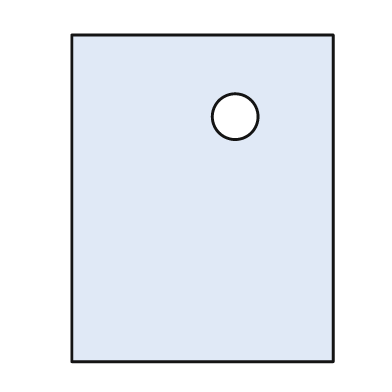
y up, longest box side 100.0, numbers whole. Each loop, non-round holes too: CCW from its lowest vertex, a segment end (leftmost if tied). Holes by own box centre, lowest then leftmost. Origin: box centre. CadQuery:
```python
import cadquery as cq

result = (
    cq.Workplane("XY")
    .moveTo(-40.0, -50.0)
    .lineTo(40.0, -50.0)
    .lineTo(40.0, 50.0)
    .lineTo(-40.0, 50.0)
    .close()
    .moveTo(10.0, 25.0)
    .circle(7.0)
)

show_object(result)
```